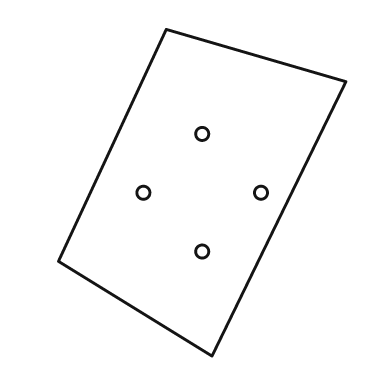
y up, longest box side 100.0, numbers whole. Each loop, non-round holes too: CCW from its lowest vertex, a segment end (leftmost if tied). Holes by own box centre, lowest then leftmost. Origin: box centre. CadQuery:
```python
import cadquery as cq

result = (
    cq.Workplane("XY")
    .moveTo(3.0, -50.0)
    .lineTo(44.0, 34.0)
    .lineTo(-11.0, 50.0)
    .lineTo(-44.0, -21.0)
    .close()
    .moveTo(0.0, -18.0)
    .circle(2.0)
    .moveTo(-18.0, 0.0)
    .circle(2.0)
    .moveTo(18.0, 0.0)
    .circle(2.0)
    .moveTo(0.0, 18.0)
    .circle(2.0)
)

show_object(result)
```